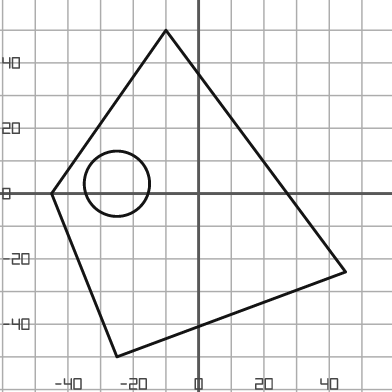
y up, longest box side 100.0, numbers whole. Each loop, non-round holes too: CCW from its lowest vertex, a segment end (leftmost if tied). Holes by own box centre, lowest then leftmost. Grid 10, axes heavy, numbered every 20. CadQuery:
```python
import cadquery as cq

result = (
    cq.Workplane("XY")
    .moveTo(-25.0, -50.0)
    .lineTo(45.0, -24.0)
    .lineTo(-10.0, 50.0)
    .lineTo(-45.0, 0.0)
    .close()
    .moveTo(-25.0, 3.0)
    .circle(10.0)
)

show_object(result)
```